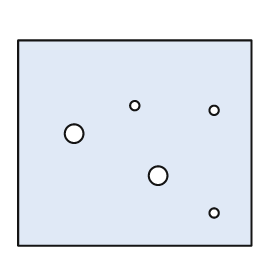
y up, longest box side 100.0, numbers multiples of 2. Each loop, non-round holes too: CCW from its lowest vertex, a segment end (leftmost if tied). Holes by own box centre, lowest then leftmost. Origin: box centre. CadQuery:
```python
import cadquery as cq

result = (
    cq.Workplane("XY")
    .moveTo(-50.0, -44.0)
    .lineTo(50.0, -44.0)
    .lineTo(50.0, 44.0)
    .lineTo(-50.0, 44.0)
    .close()
    .moveTo(34.0, -30.0)
    .circle(2.0)
    .moveTo(10.0, -14.0)
    .circle(4.0)
    .moveTo(-26.0, 4.0)
    .circle(4.0)
    .moveTo(34.0, 14.0)
    .circle(2.0)
    .moveTo(0.0, 16.0)
    .circle(2.0)
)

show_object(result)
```